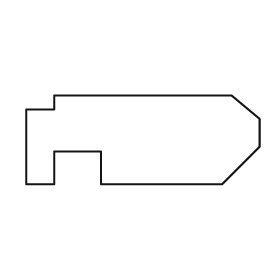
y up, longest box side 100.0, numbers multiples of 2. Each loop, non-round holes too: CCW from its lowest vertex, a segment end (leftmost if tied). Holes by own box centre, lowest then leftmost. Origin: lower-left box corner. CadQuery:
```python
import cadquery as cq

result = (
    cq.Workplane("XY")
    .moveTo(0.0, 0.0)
    .lineTo(12.0, 0.0)
    .lineTo(12.0, 14.0)
    .lineTo(32.0, 14.0)
    .lineTo(32.0, 0.0)
    .lineTo(84.0, 0.0)
    .lineTo(100.0, 16.0)
    .lineTo(100.0, 28.0)
    .lineTo(88.0, 38.0)
    .lineTo(12.0, 38.0)
    .lineTo(12.0, 32.0)
    .lineTo(0.0, 32.0)
    .close()
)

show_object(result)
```